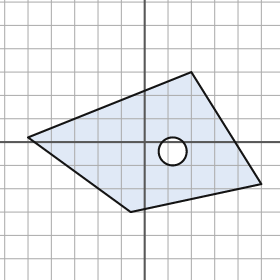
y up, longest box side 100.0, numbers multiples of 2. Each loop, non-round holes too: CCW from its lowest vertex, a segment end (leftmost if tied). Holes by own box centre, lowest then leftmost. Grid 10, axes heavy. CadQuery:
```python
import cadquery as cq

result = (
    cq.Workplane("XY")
    .moveTo(-6.0, -30.0)
    .lineTo(50.0, -18.0)
    .lineTo(20.0, 30.0)
    .lineTo(-50.0, 2.0)
    .close()
    .moveTo(12.0, -4.0)
    .circle(6.0)
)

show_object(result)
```